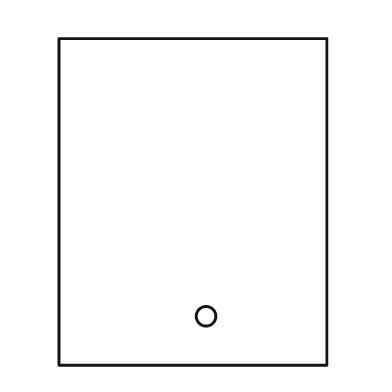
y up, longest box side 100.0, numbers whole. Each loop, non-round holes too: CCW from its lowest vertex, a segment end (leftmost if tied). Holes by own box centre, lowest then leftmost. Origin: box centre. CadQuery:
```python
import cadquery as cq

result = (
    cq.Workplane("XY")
    .moveTo(-41.0, -50.0)
    .lineTo(41.0, -50.0)
    .lineTo(41.0, 50.0)
    .lineTo(-41.0, 50.0)
    .close()
    .moveTo(4.0, -35.0)
    .circle(3.0)
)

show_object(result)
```